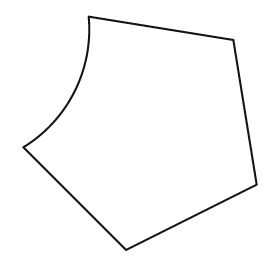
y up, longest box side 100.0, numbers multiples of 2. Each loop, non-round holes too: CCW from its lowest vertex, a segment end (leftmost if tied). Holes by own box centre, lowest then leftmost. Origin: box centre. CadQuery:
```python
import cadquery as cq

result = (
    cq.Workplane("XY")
    .moveTo(-6.0, -50.0)
    .lineTo(50.0, -22.0)
    .lineTo(40.0, 40.0)
    .lineTo(-22.0, 50.0)
    .threePointArc((-28.0, 18.0), (-50.0, -6.0))
    .close()
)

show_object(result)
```